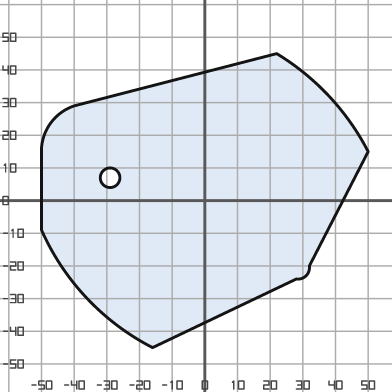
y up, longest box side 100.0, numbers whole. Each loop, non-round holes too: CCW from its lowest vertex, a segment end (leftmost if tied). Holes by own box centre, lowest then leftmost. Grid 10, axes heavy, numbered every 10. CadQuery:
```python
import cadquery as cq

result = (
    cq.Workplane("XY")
    .moveTo(-16.0, -45.0)
    .lineTo(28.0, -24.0)
    .threePointArc((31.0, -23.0), (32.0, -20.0))
    .lineTo(50.0, 15.0)
    .threePointArc((38.0, 32.0), (22.0, 45.0))
    .lineTo(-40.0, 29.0)
    .threePointArc((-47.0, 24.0), (-50.0, 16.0))
    .lineTo(-50.0, -9.0)
    .threePointArc((-36.0, -30.0), (-16.0, -45.0))
    .close()
    .moveTo(-29.0, 7.0)
    .circle(3.0)
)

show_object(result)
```